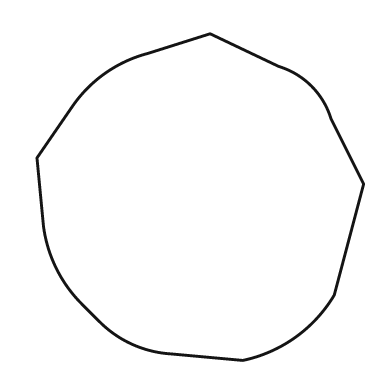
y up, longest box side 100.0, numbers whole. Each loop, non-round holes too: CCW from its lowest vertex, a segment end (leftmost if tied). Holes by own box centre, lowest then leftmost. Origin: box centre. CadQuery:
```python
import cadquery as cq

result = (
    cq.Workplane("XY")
    .moveTo(13.0, -50.0)
    .threePointArc((29.0, -43.0), (41.0, -30.0))
    .lineTo(50.0, 4.0)
    .lineTo(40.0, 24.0)
    .threePointArc((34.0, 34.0), (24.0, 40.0))
    .lineTo(3.0, 50.0)
    .lineTo(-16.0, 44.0)
    .threePointArc((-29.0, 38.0), (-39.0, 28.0))
    .lineTo(-50.0, 12.0)
    .lineTo(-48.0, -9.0)
    .threePointArc((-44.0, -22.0), (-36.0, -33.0))
    .lineTo(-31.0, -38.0)
    .threePointArc((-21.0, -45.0), (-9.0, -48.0))
    .close()
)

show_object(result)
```